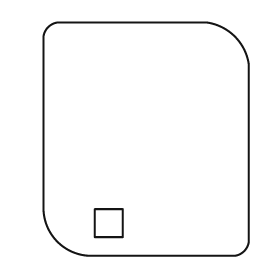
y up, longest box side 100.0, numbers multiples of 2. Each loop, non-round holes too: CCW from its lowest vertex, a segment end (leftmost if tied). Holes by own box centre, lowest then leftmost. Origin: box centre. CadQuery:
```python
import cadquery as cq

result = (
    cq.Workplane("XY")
    .moveTo(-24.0, -50.0)
    .lineTo(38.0, -50.0)
    .threePointArc((42.0, -48.0), (44.0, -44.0))
    .lineTo(44.0, 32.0)
    .threePointArc((38.0, 44.0), (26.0, 50.0))
    .lineTo(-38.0, 50.0)
    .threePointArc((-42.0, 48.0), (-44.0, 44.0))
    .lineTo(-44.0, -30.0)
    .threePointArc((-38.0, -44.0), (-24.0, -50.0))
    .close()
    .moveTo(-22.0, -42.0)
    .lineTo(-10.0, -42.0)
    .lineTo(-10.0, -30.0)
    .lineTo(-22.0, -30.0)
    .close()
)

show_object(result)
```